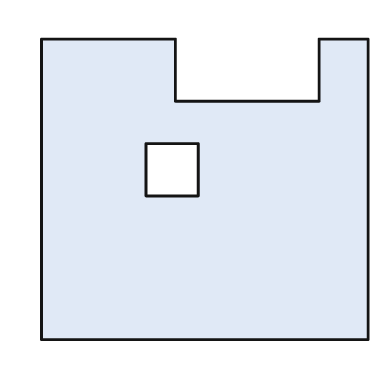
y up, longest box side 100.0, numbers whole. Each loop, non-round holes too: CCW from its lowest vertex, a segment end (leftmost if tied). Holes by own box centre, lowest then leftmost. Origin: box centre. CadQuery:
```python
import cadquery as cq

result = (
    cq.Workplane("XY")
    .moveTo(-50.0, -46.0)
    .lineTo(50.0, -46.0)
    .lineTo(50.0, 46.0)
    .lineTo(35.0, 46.0)
    .lineTo(35.0, 27.0)
    .lineTo(-9.0, 27.0)
    .lineTo(-9.0, 46.0)
    .lineTo(-50.0, 46.0)
    .close()
    .moveTo(-18.0, -2.0)
    .lineTo(-2.0, -2.0)
    .lineTo(-2.0, 14.0)
    .lineTo(-18.0, 14.0)
    .close()
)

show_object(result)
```